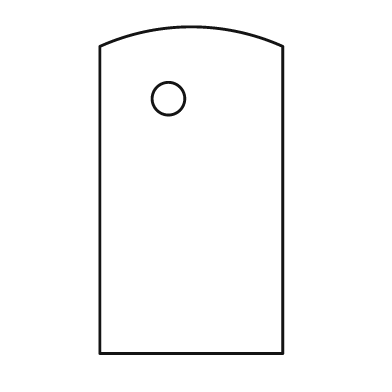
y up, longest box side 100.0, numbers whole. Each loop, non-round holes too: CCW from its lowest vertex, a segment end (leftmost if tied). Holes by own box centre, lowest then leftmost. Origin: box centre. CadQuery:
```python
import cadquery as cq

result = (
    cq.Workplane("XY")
    .moveTo(-28.0, -50.0)
    .lineTo(28.0, -50.0)
    .lineTo(28.0, 44.0)
    .threePointArc((0.0, 50.0), (-28.0, 44.0))
    .close()
    .moveTo(-7.0, 28.0)
    .circle(5.0)
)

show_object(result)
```